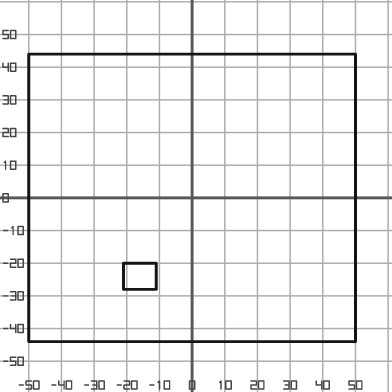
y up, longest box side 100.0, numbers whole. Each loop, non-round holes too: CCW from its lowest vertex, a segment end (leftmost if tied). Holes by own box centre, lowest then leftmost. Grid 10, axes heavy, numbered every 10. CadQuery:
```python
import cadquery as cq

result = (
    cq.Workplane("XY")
    .moveTo(-50.0, -44.0)
    .lineTo(50.0, -44.0)
    .lineTo(50.0, 44.0)
    .lineTo(-50.0, 44.0)
    .close()
    .moveTo(-21.0, -28.0)
    .lineTo(-11.0, -28.0)
    .lineTo(-11.0, -20.0)
    .lineTo(-21.0, -20.0)
    .close()
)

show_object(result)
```